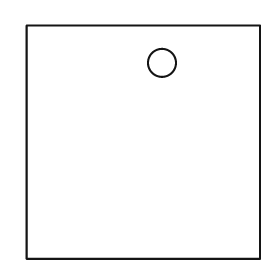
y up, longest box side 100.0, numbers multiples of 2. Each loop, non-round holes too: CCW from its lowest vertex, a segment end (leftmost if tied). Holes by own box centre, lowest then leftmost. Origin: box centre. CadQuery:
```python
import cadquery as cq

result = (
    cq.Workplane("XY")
    .moveTo(-50.0, -50.0)
    .lineTo(50.0, -50.0)
    .lineTo(50.0, 50.0)
    .lineTo(-50.0, 50.0)
    .close()
    .moveTo(8.0, 34.0)
    .circle(6.0)
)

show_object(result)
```